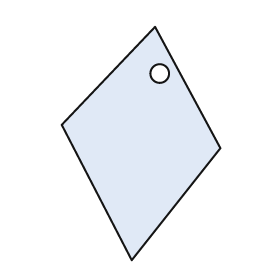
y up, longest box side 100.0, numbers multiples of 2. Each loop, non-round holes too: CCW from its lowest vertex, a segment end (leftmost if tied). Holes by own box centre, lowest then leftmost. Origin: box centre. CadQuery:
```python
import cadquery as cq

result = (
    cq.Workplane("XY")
    .moveTo(-4.0, -50.0)
    .lineTo(34.0, -2.0)
    .lineTo(6.0, 50.0)
    .lineTo(-34.0, 8.0)
    .close()
    .moveTo(8.0, 30.0)
    .circle(4.0)
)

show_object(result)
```